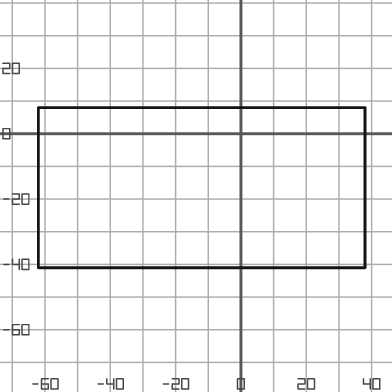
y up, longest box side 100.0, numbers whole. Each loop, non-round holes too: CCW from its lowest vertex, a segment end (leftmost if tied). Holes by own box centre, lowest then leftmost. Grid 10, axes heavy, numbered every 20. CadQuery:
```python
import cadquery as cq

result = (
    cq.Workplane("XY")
    .moveTo(-62.0, -41.0)
    .lineTo(38.0, -41.0)
    .lineTo(38.0, 8.0)
    .lineTo(-62.0, 8.0)
    .close()
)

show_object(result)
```